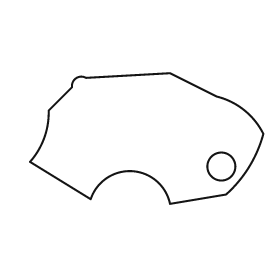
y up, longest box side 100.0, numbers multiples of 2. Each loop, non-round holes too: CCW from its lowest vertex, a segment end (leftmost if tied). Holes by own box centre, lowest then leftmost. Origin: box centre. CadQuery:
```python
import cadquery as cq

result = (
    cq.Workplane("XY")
    .moveTo(10.0, -28.0)
    .lineTo(34.0, -24.0)
    .threePointArc((44.0, -12.0), (50.0, 2.0))
    .threePointArc((42.0, 12.0), (30.0, 18.0))
    .lineTo(10.0, 28.0)
    .lineTo(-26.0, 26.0)
    .threePointArc((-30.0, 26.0), (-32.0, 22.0))
    .lineTo(-42.0, 12.0)
    .threePointArc((-44.0, 0.0), (-50.0, -10.0))
    .lineTo(-24.0, -26.0)
    .threePointArc((-6.0, -14.0), (10.0, -28.0))
    .close()
    .moveTo(32.0, -12.0)
    .circle(6.0)
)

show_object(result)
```